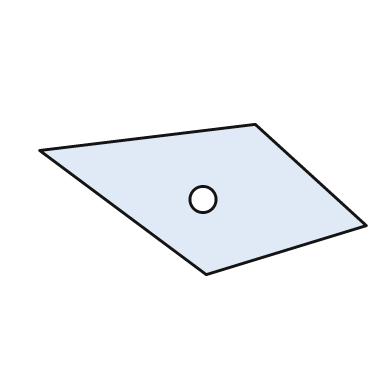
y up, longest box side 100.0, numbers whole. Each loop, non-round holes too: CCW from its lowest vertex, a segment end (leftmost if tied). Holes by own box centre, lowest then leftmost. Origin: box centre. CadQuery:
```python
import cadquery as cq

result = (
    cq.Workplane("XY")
    .moveTo(1.0, -23.0)
    .lineTo(50.0, -8.0)
    .lineTo(16.0, 23.0)
    .lineTo(-50.0, 15.0)
    .close()
    .moveTo(0.0, 0.0)
    .circle(4.0)
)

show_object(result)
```